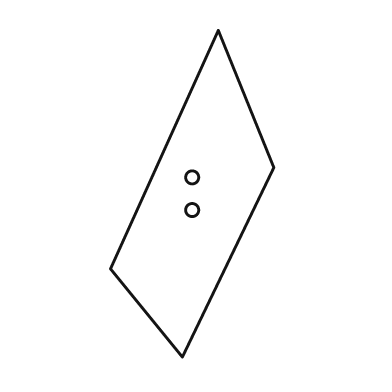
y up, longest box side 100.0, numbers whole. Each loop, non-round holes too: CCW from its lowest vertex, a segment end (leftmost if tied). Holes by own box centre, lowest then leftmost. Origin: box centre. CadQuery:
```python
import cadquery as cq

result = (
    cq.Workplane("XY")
    .moveTo(-3.0, -50.0)
    .lineTo(25.0, 8.0)
    .lineTo(8.0, 50.0)
    .lineTo(-25.0, -23.0)
    .close()
    .moveTo(0.0, -5.0)
    .circle(2.0)
    .moveTo(0.0, 5.0)
    .circle(2.0)
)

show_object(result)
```